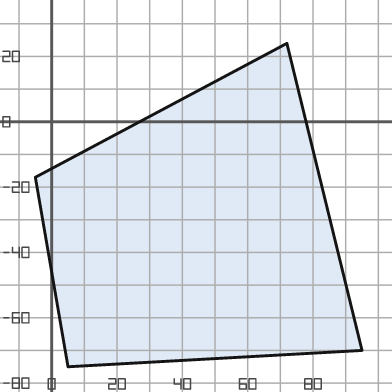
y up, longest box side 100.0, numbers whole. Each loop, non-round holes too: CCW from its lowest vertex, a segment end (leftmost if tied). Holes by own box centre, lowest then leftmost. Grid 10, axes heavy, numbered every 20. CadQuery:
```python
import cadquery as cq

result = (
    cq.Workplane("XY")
    .moveTo(5.0, -75.0)
    .lineTo(95.0, -70.0)
    .lineTo(72.0, 24.0)
    .lineTo(-5.0, -17.0)
    .close()
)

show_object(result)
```